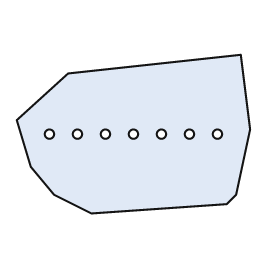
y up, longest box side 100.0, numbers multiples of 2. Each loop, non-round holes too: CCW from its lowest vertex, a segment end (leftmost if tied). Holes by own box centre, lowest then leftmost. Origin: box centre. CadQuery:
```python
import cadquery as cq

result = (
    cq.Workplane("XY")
    .moveTo(-18.0, -34.0)
    .lineTo(40.0, -30.0)
    .lineTo(44.0, -26.0)
    .lineTo(50.0, 2.0)
    .lineTo(46.0, 34.0)
    .lineTo(-28.0, 26.0)
    .lineTo(-50.0, 6.0)
    .lineTo(-44.0, -14.0)
    .lineTo(-34.0, -26.0)
    .close()
    .moveTo(-36.0, 0.0)
    .circle(2.0)
    .moveTo(-24.0, 0.0)
    .circle(2.0)
    .moveTo(-12.0, 0.0)
    .circle(2.0)
    .moveTo(0.0, 0.0)
    .circle(2.0)
    .moveTo(12.0, 0.0)
    .circle(2.0)
    .moveTo(24.0, 0.0)
    .circle(2.0)
    .moveTo(36.0, 0.0)
    .circle(2.0)
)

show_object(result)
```